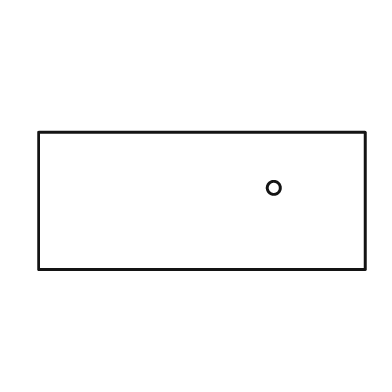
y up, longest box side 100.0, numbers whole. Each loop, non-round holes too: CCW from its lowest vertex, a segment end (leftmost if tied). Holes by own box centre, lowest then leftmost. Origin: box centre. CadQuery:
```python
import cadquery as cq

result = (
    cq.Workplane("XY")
    .moveTo(-50.0, -21.0)
    .lineTo(50.0, -21.0)
    .lineTo(50.0, 21.0)
    .lineTo(-50.0, 21.0)
    .close()
    .moveTo(22.0, 4.0)
    .circle(2.0)
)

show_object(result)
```